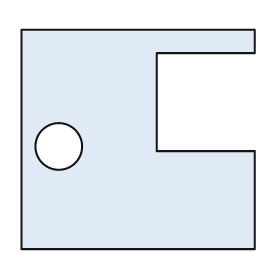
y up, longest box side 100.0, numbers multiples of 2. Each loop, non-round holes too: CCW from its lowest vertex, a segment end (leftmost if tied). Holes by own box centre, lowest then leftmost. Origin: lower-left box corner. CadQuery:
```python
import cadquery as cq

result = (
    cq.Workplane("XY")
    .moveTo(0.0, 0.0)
    .lineTo(100.0, 0.0)
    .lineTo(100.0, 42.0)
    .lineTo(58.0, 42.0)
    .lineTo(58.0, 84.0)
    .lineTo(100.0, 84.0)
    .lineTo(100.0, 94.0)
    .lineTo(0.0, 94.0)
    .close()
    .moveTo(16.0, 44.0)
    .circle(10.0)
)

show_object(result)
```